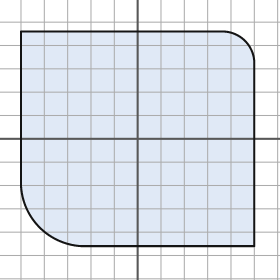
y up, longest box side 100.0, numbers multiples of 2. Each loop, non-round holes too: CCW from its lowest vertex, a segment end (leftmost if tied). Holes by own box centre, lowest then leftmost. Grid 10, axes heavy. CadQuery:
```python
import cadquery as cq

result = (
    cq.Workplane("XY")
    .moveTo(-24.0, -46.0)
    .lineTo(50.0, -46.0)
    .lineTo(50.0, 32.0)
    .threePointArc((46.0, 42.0), (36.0, 46.0))
    .lineTo(-50.0, 46.0)
    .lineTo(-50.0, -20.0)
    .threePointArc((-42.0, -38.0), (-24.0, -46.0))
    .close()
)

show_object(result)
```